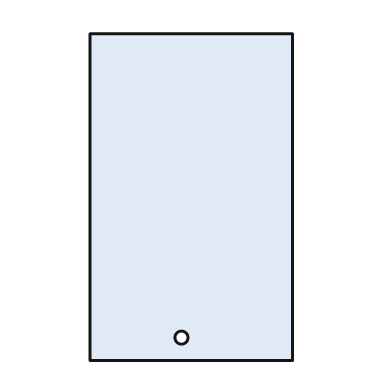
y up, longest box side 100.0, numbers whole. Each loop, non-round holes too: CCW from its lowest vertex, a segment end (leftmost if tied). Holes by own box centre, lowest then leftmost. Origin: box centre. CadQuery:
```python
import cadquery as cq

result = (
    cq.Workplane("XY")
    .moveTo(-31.0, -50.0)
    .lineTo(31.0, -50.0)
    .lineTo(31.0, 50.0)
    .lineTo(-31.0, 50.0)
    .close()
    .moveTo(-3.0, -43.0)
    .circle(2.0)
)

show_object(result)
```